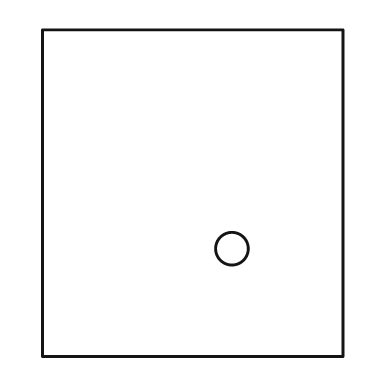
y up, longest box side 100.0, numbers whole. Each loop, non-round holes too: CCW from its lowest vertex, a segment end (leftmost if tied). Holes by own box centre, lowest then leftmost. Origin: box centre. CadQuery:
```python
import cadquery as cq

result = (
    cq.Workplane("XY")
    .moveTo(-46.0, -50.0)
    .lineTo(46.0, -50.0)
    .lineTo(46.0, 50.0)
    .lineTo(-46.0, 50.0)
    .close()
    .moveTo(12.0, -17.0)
    .circle(5.0)
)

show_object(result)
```